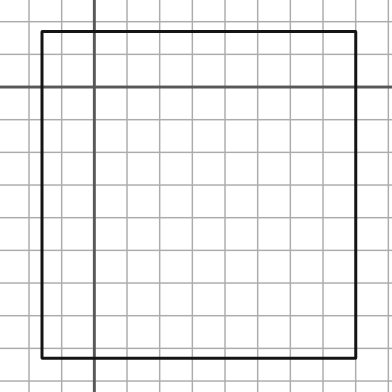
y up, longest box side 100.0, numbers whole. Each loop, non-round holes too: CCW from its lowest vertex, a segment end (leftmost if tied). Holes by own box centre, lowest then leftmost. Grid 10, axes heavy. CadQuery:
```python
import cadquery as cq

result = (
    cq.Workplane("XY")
    .moveTo(-16.0, -83.0)
    .lineTo(80.0, -83.0)
    .lineTo(80.0, 17.0)
    .lineTo(-16.0, 17.0)
    .close()
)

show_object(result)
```